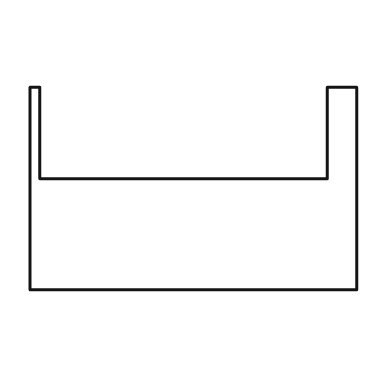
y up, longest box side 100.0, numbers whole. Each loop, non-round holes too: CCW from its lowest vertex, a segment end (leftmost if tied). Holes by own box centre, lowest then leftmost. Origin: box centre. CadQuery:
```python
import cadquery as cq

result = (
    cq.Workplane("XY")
    .moveTo(-50.0, -31.0)
    .lineTo(50.0, -31.0)
    .lineTo(50.0, 31.0)
    .lineTo(41.0, 31.0)
    .lineTo(41.0, 3.0)
    .lineTo(-47.0, 3.0)
    .lineTo(-47.0, 31.0)
    .lineTo(-50.0, 31.0)
    .close()
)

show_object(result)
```